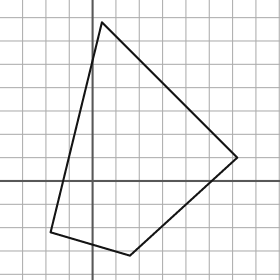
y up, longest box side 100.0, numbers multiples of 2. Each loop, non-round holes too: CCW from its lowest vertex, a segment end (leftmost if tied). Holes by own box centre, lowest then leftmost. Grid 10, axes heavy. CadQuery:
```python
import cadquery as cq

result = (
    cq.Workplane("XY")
    .moveTo(16.0, -32.0)
    .lineTo(62.0, 10.0)
    .lineTo(4.0, 68.0)
    .lineTo(-18.0, -22.0)
    .close()
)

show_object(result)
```